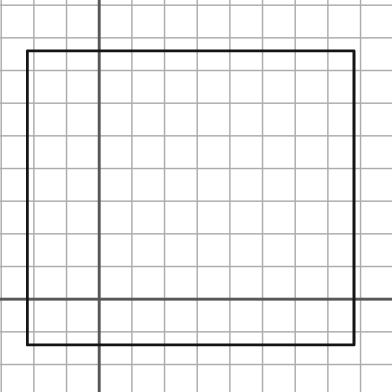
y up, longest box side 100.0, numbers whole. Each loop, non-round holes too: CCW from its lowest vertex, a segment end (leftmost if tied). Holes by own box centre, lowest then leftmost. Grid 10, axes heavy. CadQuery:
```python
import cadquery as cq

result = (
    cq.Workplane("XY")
    .moveTo(-22.0, -14.0)
    .lineTo(78.0, -14.0)
    .lineTo(78.0, 76.0)
    .lineTo(-22.0, 76.0)
    .close()
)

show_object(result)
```